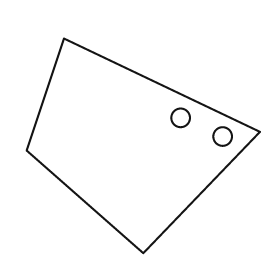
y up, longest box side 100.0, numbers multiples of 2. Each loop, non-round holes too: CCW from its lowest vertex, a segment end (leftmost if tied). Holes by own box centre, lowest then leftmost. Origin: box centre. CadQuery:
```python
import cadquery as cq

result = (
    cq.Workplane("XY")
    .moveTo(0.0, -46.0)
    .lineTo(50.0, 6.0)
    .lineTo(-34.0, 46.0)
    .lineTo(-50.0, -2.0)
    .close()
    .moveTo(34.0, 4.0)
    .circle(4.0)
    .moveTo(16.0, 12.0)
    .circle(4.0)
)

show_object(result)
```